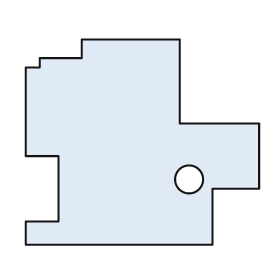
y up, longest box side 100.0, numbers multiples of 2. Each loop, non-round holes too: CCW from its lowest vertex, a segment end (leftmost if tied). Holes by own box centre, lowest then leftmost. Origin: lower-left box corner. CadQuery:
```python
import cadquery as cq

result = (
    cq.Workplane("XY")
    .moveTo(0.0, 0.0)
    .lineTo(80.0, 0.0)
    .lineTo(80.0, 24.0)
    .lineTo(100.0, 24.0)
    .lineTo(100.0, 52.0)
    .lineTo(66.0, 52.0)
    .lineTo(66.0, 88.0)
    .lineTo(24.0, 88.0)
    .lineTo(24.0, 80.0)
    .lineTo(6.0, 80.0)
    .lineTo(6.0, 76.0)
    .lineTo(0.0, 76.0)
    .lineTo(0.0, 38.0)
    .lineTo(14.0, 38.0)
    .lineTo(14.0, 10.0)
    .lineTo(0.0, 10.0)
    .close()
    .moveTo(70.0, 28.0)
    .circle(6.0)
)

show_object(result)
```